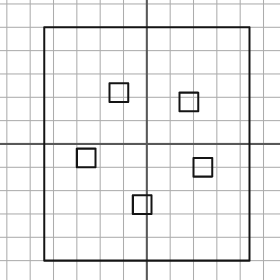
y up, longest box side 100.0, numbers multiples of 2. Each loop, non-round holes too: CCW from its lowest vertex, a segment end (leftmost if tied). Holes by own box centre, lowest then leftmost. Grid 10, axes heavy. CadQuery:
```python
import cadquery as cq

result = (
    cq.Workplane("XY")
    .moveTo(-44.0, -50.0)
    .lineTo(44.0, -50.0)
    .lineTo(44.0, 50.0)
    .lineTo(-44.0, 50.0)
    .close()
    .moveTo(-6.0, -30.0)
    .lineTo(2.0, -30.0)
    .lineTo(2.0, -22.0)
    .lineTo(-6.0, -22.0)
    .close()
    .moveTo(20.0, -14.0)
    .lineTo(28.0, -14.0)
    .lineTo(28.0, -6.0)
    .lineTo(20.0, -6.0)
    .close()
    .moveTo(-30.0, -10.0)
    .lineTo(-22.0, -10.0)
    .lineTo(-22.0, -2.0)
    .lineTo(-30.0, -2.0)
    .close()
    .moveTo(14.0, 14.0)
    .lineTo(22.0, 14.0)
    .lineTo(22.0, 22.0)
    .lineTo(14.0, 22.0)
    .close()
    .moveTo(-16.0, 18.0)
    .lineTo(-8.0, 18.0)
    .lineTo(-8.0, 26.0)
    .lineTo(-16.0, 26.0)
    .close()
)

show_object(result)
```